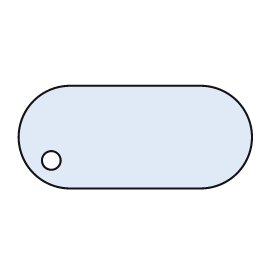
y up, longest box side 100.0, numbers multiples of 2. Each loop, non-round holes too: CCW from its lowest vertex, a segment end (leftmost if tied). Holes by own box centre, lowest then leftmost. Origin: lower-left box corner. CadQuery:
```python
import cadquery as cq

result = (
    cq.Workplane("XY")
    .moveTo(22.0, 0.0)
    .lineTo(78.0, 0.0)
    .threePointArc((100.0, 22.0), (78.0, 44.0))
    .lineTo(22.0, 44.0)
    .threePointArc((0.0, 22.0), (22.0, 0.0))
    .close()
    .moveTo(14.0, 12.0)
    .circle(4.0)
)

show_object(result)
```